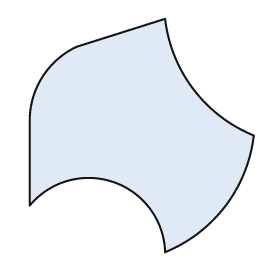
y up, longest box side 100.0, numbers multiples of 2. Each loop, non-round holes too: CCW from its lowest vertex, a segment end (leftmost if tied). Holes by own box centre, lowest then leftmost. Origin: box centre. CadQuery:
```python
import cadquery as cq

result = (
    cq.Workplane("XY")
    .moveTo(10.0, -50.0)
    .threePointArc((36.0, -30.0), (48.0, 0.0))
    .threePointArc((22.0, 20.0), (10.0, 50.0))
    .lineTo(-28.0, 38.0)
    .threePointArc((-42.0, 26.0), (-48.0, 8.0))
    .lineTo(-48.0, -30.0)
    .threePointArc((-12.0, -20.0), (10.0, -50.0))
    .close()
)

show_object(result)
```